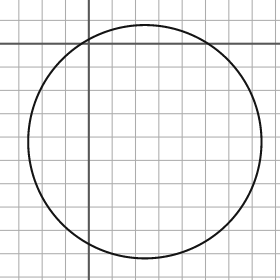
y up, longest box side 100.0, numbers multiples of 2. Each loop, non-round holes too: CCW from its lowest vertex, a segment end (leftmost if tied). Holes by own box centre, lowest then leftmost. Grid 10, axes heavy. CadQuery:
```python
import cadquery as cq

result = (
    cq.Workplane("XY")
    .moveTo(24.0, -42.0)
    .circle(50.0)
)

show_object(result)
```